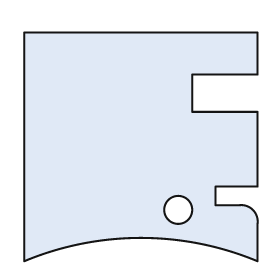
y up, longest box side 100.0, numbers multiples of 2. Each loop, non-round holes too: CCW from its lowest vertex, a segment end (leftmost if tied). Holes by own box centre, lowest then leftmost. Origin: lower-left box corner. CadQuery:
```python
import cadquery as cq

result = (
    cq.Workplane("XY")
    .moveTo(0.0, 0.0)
    .threePointArc((50.0, 10.0), (100.0, 0.0))
    .lineTo(100.0, 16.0)
    .threePointArc((98.0, 22.0), (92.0, 24.0))
    .lineTo(82.0, 24.0)
    .lineTo(82.0, 32.0)
    .lineTo(100.0, 32.0)
    .lineTo(100.0, 64.0)
    .lineTo(72.0, 64.0)
    .lineTo(72.0, 80.0)
    .lineTo(100.0, 80.0)
    .lineTo(100.0, 98.0)
    .lineTo(0.0, 98.0)
    .close()
    .moveTo(66.0, 22.0)
    .circle(6.0)
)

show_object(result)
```